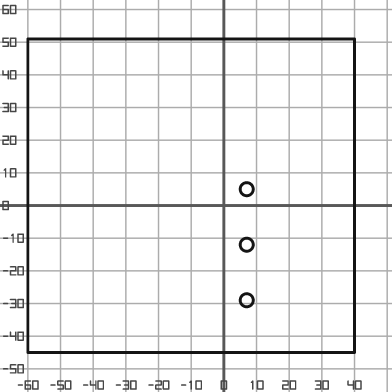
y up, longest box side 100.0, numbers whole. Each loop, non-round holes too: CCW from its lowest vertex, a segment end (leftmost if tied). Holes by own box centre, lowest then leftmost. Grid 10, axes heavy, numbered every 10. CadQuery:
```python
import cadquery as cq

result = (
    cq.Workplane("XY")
    .moveTo(-60.0, -45.0)
    .lineTo(40.0, -45.0)
    .lineTo(40.0, 51.0)
    .lineTo(-60.0, 51.0)
    .close()
    .moveTo(7.0, -29.0)
    .circle(2.0)
    .moveTo(7.0, -12.0)
    .circle(2.0)
    .moveTo(7.0, 5.0)
    .circle(2.0)
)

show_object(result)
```